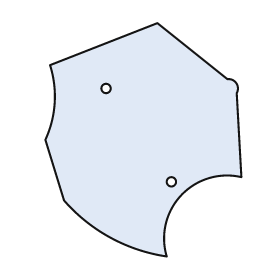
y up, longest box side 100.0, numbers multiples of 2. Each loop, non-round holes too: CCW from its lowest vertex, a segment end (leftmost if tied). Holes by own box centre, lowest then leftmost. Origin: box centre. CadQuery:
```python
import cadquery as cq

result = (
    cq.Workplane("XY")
    .moveTo(10.0, -50.0)
    .threePointArc((16.0, -24.0), (42.0, -16.0))
    .lineTo(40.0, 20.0)
    .threePointArc((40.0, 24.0), (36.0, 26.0))
    .lineTo(6.0, 50.0)
    .lineTo(-40.0, 32.0)
    .threePointArc((-38.0, 16.0), (-42.0, 0.0))
    .lineTo(-34.0, -26.0)
    .threePointArc((-14.0, -42.0), (10.0, -50.0))
    .close()
    .moveTo(12.0, -18.0)
    .circle(2.0)
    .moveTo(-16.0, 22.0)
    .circle(2.0)
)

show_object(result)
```